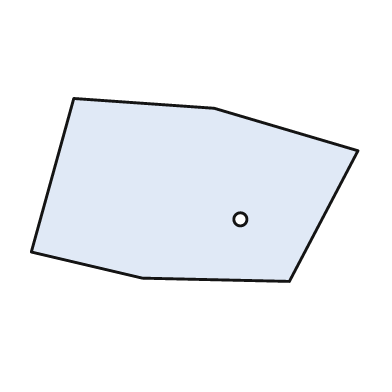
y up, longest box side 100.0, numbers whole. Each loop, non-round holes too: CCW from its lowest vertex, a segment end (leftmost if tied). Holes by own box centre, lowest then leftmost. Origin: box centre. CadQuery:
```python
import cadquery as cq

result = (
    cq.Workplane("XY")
    .moveTo(29.0, -28.0)
    .lineTo(50.0, 12.0)
    .lineTo(6.0, 25.0)
    .lineTo(-37.0, 28.0)
    .lineTo(-50.0, -19.0)
    .lineTo(-16.0, -27.0)
    .close()
    .moveTo(14.0, -9.0)
    .circle(2.0)
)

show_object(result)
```